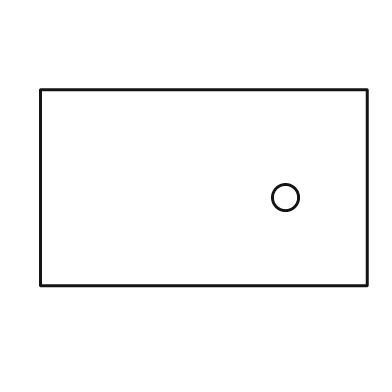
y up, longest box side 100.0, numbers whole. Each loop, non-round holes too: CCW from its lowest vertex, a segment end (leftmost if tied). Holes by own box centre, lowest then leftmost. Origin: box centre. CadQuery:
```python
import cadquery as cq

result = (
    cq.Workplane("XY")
    .moveTo(-50.0, -30.0)
    .lineTo(50.0, -30.0)
    .lineTo(50.0, 30.0)
    .lineTo(-50.0, 30.0)
    .close()
    .moveTo(25.0, -3.0)
    .circle(4.0)
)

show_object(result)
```